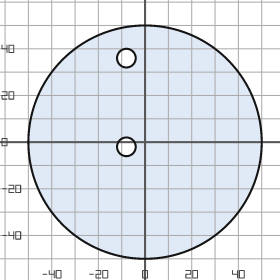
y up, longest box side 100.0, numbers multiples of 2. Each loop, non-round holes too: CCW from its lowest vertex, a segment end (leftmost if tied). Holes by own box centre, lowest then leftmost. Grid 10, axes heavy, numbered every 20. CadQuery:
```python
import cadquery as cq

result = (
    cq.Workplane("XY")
    .moveTo(0.0, 0.0)
    .circle(50.0)
    .moveTo(-8.0, -2.0)
    .circle(4.0)
    .moveTo(-8.0, 36.0)
    .circle(4.0)
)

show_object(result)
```